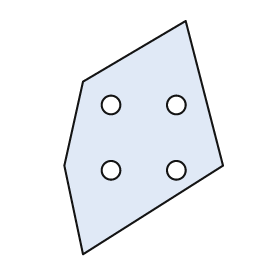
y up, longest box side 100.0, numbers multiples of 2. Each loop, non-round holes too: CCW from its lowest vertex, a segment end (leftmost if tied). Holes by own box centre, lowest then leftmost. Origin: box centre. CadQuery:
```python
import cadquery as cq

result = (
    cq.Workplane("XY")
    .moveTo(-26.0, -50.0)
    .lineTo(34.0, -12.0)
    .lineTo(18.0, 50.0)
    .lineTo(-26.0, 24.0)
    .lineTo(-34.0, -12.0)
    .close()
    .moveTo(-14.0, -14.0)
    .circle(4.0)
    .moveTo(14.0, -14.0)
    .circle(4.0)
    .moveTo(-14.0, 14.0)
    .circle(4.0)
    .moveTo(14.0, 14.0)
    .circle(4.0)
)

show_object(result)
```